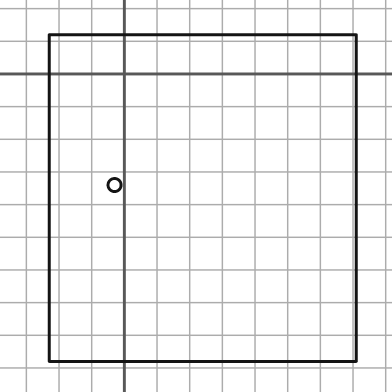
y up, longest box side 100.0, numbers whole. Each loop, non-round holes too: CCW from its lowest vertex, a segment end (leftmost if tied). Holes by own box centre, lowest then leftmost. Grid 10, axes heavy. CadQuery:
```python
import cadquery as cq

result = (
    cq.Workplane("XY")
    .moveTo(-23.0, -88.0)
    .lineTo(71.0, -88.0)
    .lineTo(71.0, 12.0)
    .lineTo(-23.0, 12.0)
    .close()
    .moveTo(-3.0, -34.0)
    .circle(2.0)
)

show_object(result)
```